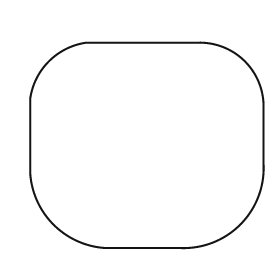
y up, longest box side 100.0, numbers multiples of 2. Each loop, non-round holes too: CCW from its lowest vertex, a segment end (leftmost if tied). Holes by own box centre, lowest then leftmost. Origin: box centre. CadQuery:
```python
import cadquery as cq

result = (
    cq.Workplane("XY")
    .moveTo(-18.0, -44.0)
    .lineTo(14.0, -44.0)
    .threePointArc((40.0, -34.0), (50.0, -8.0))
    .lineTo(50.0, 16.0)
    .threePointArc((42.0, 36.0), (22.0, 44.0))
    .lineTo(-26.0, 44.0)
    .threePointArc((-42.0, 36.0), (-50.0, 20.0))
    .lineTo(-50.0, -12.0)
    .threePointArc((-40.0, -34.0), (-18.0, -44.0))
    .close()
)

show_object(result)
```